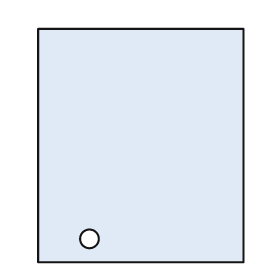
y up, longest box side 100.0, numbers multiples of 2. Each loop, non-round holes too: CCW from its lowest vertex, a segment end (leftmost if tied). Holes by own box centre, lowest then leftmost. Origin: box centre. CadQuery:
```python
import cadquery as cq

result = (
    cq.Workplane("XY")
    .moveTo(-44.0, -50.0)
    .lineTo(44.0, -50.0)
    .lineTo(44.0, 50.0)
    .lineTo(-44.0, 50.0)
    .close()
    .moveTo(-22.0, -40.0)
    .circle(4.0)
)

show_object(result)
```